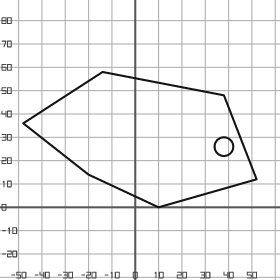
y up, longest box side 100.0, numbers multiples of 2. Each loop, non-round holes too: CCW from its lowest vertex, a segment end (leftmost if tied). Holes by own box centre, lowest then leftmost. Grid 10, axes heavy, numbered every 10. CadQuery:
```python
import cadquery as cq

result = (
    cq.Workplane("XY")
    .moveTo(10.0, 0.0)
    .lineTo(52.0, 12.0)
    .lineTo(38.0, 48.0)
    .lineTo(-14.0, 58.0)
    .lineTo(-48.0, 36.0)
    .lineTo(-20.0, 14.0)
    .close()
    .moveTo(38.0, 26.0)
    .circle(4.0)
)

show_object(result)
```